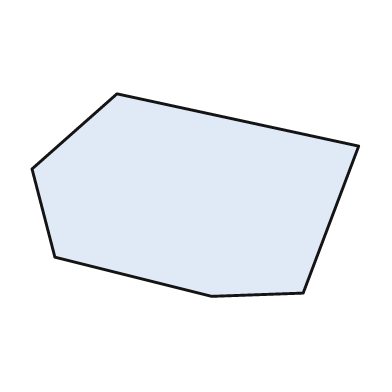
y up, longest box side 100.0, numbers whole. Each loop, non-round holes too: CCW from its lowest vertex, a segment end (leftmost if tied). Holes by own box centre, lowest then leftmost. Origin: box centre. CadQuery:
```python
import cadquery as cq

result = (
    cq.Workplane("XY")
    .moveTo(5.0, -31.0)
    .lineTo(33.0, -30.0)
    .lineTo(50.0, 15.0)
    .lineTo(-24.0, 31.0)
    .lineTo(-50.0, 8.0)
    .lineTo(-43.0, -19.0)
    .close()
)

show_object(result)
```